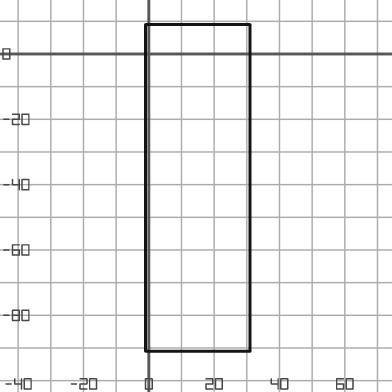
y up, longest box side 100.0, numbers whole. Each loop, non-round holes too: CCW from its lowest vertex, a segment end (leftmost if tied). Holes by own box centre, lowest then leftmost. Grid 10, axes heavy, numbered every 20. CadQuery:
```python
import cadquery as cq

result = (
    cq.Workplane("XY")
    .moveTo(-1.0, -91.0)
    .lineTo(31.0, -91.0)
    .lineTo(31.0, 9.0)
    .lineTo(-1.0, 9.0)
    .close()
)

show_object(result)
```